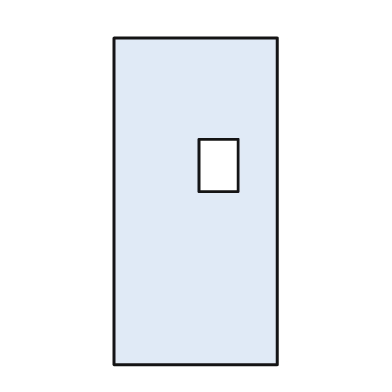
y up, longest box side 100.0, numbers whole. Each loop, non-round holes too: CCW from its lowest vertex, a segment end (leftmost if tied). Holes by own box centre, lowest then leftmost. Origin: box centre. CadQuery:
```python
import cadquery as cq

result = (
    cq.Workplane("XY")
    .moveTo(-25.0, -50.0)
    .lineTo(25.0, -50.0)
    .lineTo(25.0, 50.0)
    .lineTo(-25.0, 50.0)
    .close()
    .moveTo(1.0, 3.0)
    .lineTo(13.0, 3.0)
    .lineTo(13.0, 19.0)
    .lineTo(1.0, 19.0)
    .close()
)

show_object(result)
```